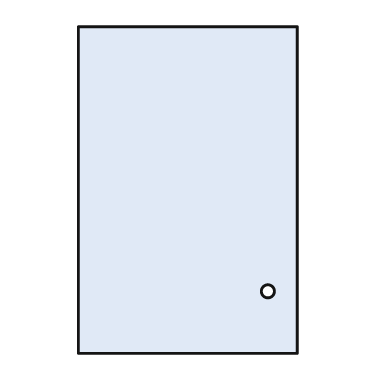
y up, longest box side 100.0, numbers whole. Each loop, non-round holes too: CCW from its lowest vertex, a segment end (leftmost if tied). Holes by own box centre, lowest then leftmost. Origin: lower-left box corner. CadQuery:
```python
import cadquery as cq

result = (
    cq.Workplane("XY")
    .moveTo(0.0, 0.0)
    .lineTo(67.0, 0.0)
    .lineTo(67.0, 100.0)
    .lineTo(0.0, 100.0)
    .close()
    .moveTo(58.0, 19.0)
    .circle(2.0)
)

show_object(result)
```